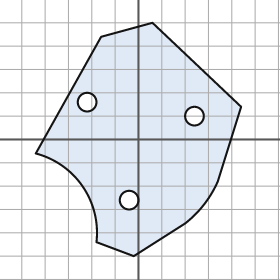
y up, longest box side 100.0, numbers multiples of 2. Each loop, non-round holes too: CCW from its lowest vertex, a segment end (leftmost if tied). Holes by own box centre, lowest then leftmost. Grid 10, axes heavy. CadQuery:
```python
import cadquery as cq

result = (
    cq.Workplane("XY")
    .moveTo(-2.0, -50.0)
    .lineTo(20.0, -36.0)
    .threePointArc((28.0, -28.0), (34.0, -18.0))
    .lineTo(44.0, 14.0)
    .lineTo(6.0, 50.0)
    .lineTo(-16.0, 44.0)
    .lineTo(-44.0, -6.0)
    .threePointArc((-24.0, -20.0), (-18.0, -44.0))
    .close()
    .moveTo(-4.0, -26.0)
    .circle(4.0)
    .moveTo(24.0, 10.0)
    .circle(4.0)
    .moveTo(-22.0, 16.0)
    .circle(4.0)
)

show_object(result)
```